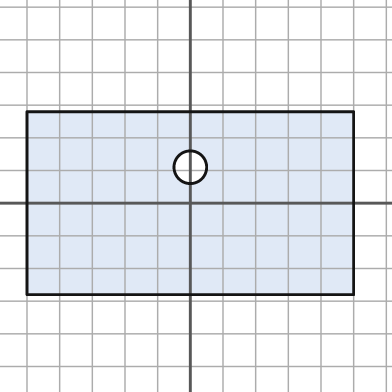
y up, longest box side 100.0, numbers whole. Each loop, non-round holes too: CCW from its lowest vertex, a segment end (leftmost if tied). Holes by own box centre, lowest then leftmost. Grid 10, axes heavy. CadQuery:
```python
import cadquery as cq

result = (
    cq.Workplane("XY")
    .moveTo(-50.0, -28.0)
    .lineTo(50.0, -28.0)
    .lineTo(50.0, 28.0)
    .lineTo(-50.0, 28.0)
    .close()
    .moveTo(0.0, 11.0)
    .circle(5.0)
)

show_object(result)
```